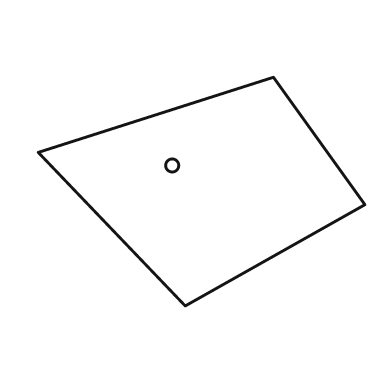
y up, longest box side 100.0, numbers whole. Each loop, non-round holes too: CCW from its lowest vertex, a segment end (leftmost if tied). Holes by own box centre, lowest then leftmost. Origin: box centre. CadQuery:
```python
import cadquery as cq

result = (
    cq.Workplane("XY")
    .moveTo(-5.0, -35.0)
    .lineTo(50.0, -4.0)
    .lineTo(22.0, 35.0)
    .lineTo(-50.0, 12.0)
    .close()
    .moveTo(-9.0, 8.0)
    .circle(2.0)
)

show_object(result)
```